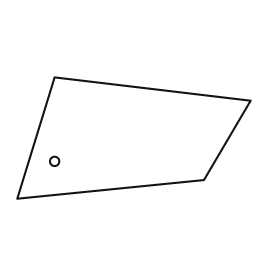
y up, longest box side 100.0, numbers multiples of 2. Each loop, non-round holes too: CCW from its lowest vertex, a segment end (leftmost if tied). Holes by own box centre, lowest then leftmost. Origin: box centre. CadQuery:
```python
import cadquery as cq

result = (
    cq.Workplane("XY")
    .moveTo(-50.0, -26.0)
    .lineTo(30.0, -18.0)
    .lineTo(50.0, 16.0)
    .lineTo(-34.0, 26.0)
    .close()
    .moveTo(-34.0, -10.0)
    .circle(2.0)
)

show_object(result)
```